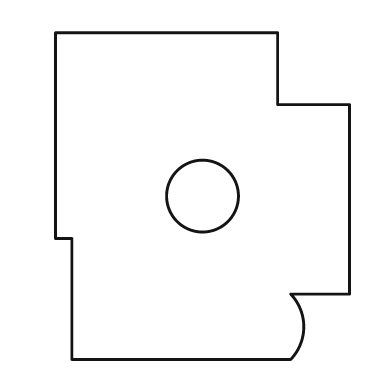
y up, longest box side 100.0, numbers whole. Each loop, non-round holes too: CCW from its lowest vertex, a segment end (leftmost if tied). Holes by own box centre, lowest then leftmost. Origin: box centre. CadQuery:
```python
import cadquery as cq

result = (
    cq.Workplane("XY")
    .moveTo(-40.0, -50.0)
    .lineTo(27.0, -50.0)
    .threePointArc((31.0, -40.0), (27.0, -30.0))
    .lineTo(45.0, -30.0)
    .lineTo(45.0, 28.0)
    .lineTo(23.0, 28.0)
    .lineTo(23.0, 50.0)
    .lineTo(-45.0, 50.0)
    .lineTo(-45.0, -13.0)
    .lineTo(-40.0, -13.0)
    .close()
    .moveTo(0.0, 0.0)
    .circle(11.0)
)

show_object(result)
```